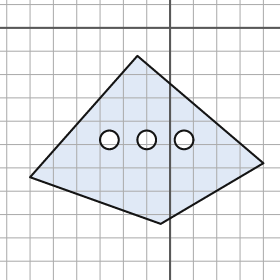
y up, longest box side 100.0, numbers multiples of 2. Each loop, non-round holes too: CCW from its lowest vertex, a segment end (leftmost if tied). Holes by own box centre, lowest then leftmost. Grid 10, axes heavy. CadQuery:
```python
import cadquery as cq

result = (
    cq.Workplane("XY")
    .moveTo(-4.0, -84.0)
    .lineTo(40.0, -58.0)
    .lineTo(-14.0, -12.0)
    .lineTo(-60.0, -64.0)
    .close()
    .moveTo(-26.0, -48.0)
    .circle(4.0)
    .moveTo(-10.0, -48.0)
    .circle(4.0)
    .moveTo(6.0, -48.0)
    .circle(4.0)
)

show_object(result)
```